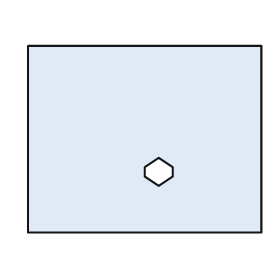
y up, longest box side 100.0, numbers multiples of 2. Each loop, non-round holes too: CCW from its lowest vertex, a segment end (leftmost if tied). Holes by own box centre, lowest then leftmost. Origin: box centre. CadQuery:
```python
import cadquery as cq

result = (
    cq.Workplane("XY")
    .moveTo(-50.0, -40.0)
    .lineTo(50.0, -40.0)
    .lineTo(50.0, 40.0)
    .lineTo(-50.0, 40.0)
    .close()
    .moveTo(6.0, -20.0)
    .lineTo(12.0, -16.0)
    .lineTo(12.0, -12.0)
    .lineTo(6.0, -8.0)
    .lineTo(0.0, -12.0)
    .lineTo(0.0, -16.0)
    .close()
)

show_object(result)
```